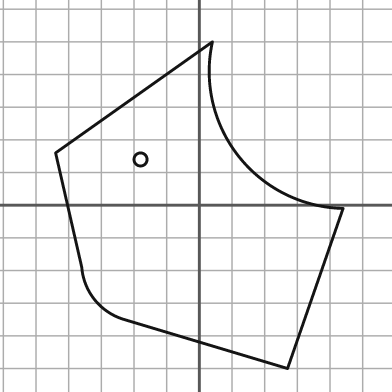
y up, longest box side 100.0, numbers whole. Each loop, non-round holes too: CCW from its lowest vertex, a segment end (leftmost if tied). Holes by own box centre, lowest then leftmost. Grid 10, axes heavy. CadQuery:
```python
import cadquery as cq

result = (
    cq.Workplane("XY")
    .moveTo(27.0, -50.0)
    .lineTo(44.0, -1.0)
    .threePointArc((12.0, 15.0), (4.0, 50.0))
    .lineTo(-44.0, 16.0)
    .lineTo(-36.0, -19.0)
    .threePointArc((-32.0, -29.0), (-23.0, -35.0))
    .close()
    .moveTo(-18.0, 14.0)
    .circle(2.0)
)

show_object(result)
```